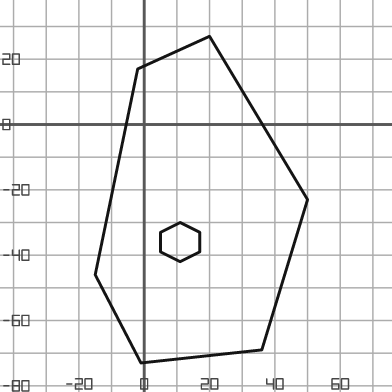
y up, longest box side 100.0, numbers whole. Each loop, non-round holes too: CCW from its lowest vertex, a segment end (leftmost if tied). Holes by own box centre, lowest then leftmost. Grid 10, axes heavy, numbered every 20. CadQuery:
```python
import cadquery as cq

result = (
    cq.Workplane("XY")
    .moveTo(-1.0, -73.0)
    .lineTo(36.0, -69.0)
    .lineTo(50.0, -23.0)
    .lineTo(20.0, 27.0)
    .lineTo(-2.0, 17.0)
    .lineTo(-15.0, -46.0)
    .close()
    .moveTo(11.0, -42.0)
    .lineTo(17.0, -39.0)
    .lineTo(17.0, -33.0)
    .lineTo(11.0, -30.0)
    .lineTo(5.0, -33.0)
    .lineTo(5.0, -39.0)
    .close()
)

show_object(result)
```